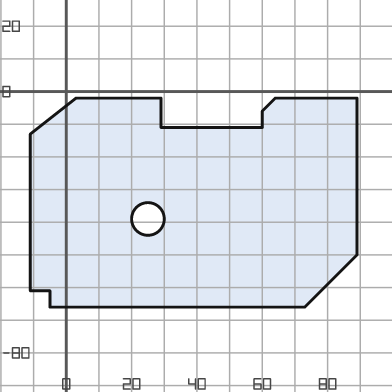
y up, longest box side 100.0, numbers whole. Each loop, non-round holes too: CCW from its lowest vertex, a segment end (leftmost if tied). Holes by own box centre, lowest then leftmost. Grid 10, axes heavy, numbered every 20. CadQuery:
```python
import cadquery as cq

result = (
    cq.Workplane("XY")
    .moveTo(-5.0, -66.0)
    .lineTo(73.0, -66.0)
    .lineTo(89.0, -50.0)
    .lineTo(89.0, -2.0)
    .lineTo(64.0, -2.0)
    .lineTo(60.0, -6.0)
    .lineTo(60.0, -11.0)
    .lineTo(29.0, -11.0)
    .lineTo(29.0, -2.0)
    .lineTo(3.0, -2.0)
    .lineTo(-11.0, -13.0)
    .lineTo(-11.0, -61.0)
    .lineTo(-5.0, -61.0)
    .close()
    .moveTo(25.0, -39.0)
    .circle(5.0)
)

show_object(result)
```